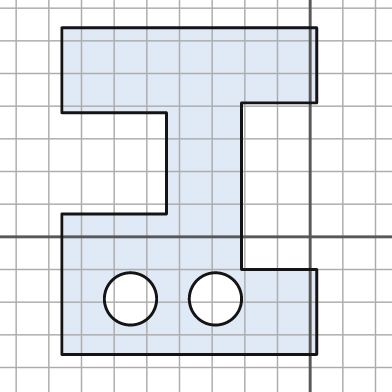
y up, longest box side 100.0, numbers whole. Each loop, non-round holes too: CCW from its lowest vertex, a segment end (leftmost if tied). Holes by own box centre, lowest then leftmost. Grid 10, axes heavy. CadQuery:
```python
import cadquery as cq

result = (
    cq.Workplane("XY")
    .moveTo(-76.0, -36.0)
    .lineTo(2.0, -36.0)
    .lineTo(2.0, -10.0)
    .lineTo(-21.0, -10.0)
    .lineTo(-21.0, 41.0)
    .lineTo(2.0, 41.0)
    .lineTo(2.0, 64.0)
    .lineTo(-76.0, 64.0)
    .lineTo(-76.0, 38.0)
    .lineTo(-44.0, 38.0)
    .lineTo(-44.0, 7.0)
    .lineTo(-76.0, 7.0)
    .close()
    .moveTo(-55.0, -19.0)
    .circle(8.0)
    .moveTo(-29.0, -19.0)
    .circle(8.0)
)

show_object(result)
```